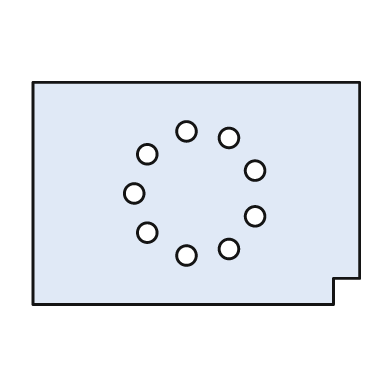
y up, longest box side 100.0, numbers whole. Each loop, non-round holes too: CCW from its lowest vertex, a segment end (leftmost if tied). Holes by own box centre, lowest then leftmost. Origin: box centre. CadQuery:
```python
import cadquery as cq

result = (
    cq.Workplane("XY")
    .moveTo(-50.0, -34.0)
    .lineTo(42.0, -34.0)
    .lineTo(42.0, -26.0)
    .lineTo(50.0, -26.0)
    .lineTo(50.0, 34.0)
    .lineTo(-50.0, 34.0)
    .close()
    .moveTo(-3.0, -19.0)
    .circle(3.0)
    .moveTo(10.0, -17.0)
    .circle(3.0)
    .moveTo(-15.0, -12.0)
    .circle(3.0)
    .moveTo(18.0, -7.0)
    .circle(3.0)
    .moveTo(-19.0, 0.0)
    .circle(3.0)
    .moveTo(18.0, 7.0)
    .circle(3.0)
    .moveTo(-15.0, 12.0)
    .circle(3.0)
    .moveTo(10.0, 17.0)
    .circle(3.0)
    .moveTo(-3.0, 19.0)
    .circle(3.0)
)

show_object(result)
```